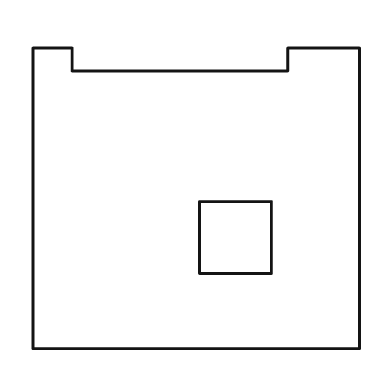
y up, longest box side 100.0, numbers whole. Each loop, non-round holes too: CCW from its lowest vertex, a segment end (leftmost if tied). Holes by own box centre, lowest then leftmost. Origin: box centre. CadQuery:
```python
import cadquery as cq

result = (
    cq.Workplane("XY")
    .moveTo(-50.0, -46.0)
    .lineTo(50.0, -46.0)
    .lineTo(50.0, 46.0)
    .lineTo(28.0, 46.0)
    .lineTo(28.0, 39.0)
    .lineTo(-38.0, 39.0)
    .lineTo(-38.0, 46.0)
    .lineTo(-50.0, 46.0)
    .close()
    .moveTo(1.0, -23.0)
    .lineTo(23.0, -23.0)
    .lineTo(23.0, -1.0)
    .lineTo(1.0, -1.0)
    .close()
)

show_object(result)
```